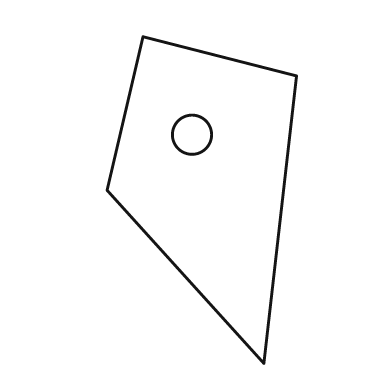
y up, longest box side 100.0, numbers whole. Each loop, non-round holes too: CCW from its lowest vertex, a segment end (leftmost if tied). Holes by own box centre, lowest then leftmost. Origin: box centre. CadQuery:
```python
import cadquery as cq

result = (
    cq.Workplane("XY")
    .moveTo(19.0, -50.0)
    .lineTo(29.0, 38.0)
    .lineTo(-18.0, 50.0)
    .lineTo(-29.0, 3.0)
    .close()
    .moveTo(-3.0, 20.0)
    .circle(6.0)
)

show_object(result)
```